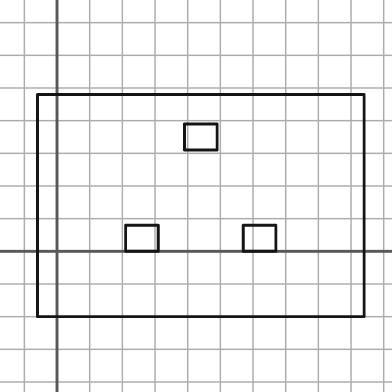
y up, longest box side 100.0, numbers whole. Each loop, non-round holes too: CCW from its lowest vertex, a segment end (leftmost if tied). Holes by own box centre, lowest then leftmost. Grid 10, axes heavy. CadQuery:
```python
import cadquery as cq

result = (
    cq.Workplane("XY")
    .moveTo(-6.0, -20.0)
    .lineTo(94.0, -20.0)
    .lineTo(94.0, 48.0)
    .lineTo(-6.0, 48.0)
    .close()
    .moveTo(21.0, 0.0)
    .lineTo(31.0, 0.0)
    .lineTo(31.0, 8.0)
    .lineTo(21.0, 8.0)
    .close()
    .moveTo(57.0, 0.0)
    .lineTo(67.0, 0.0)
    .lineTo(67.0, 8.0)
    .lineTo(57.0, 8.0)
    .close()
    .moveTo(39.0, 31.0)
    .lineTo(49.0, 31.0)
    .lineTo(49.0, 39.0)
    .lineTo(39.0, 39.0)
    .close()
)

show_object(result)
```